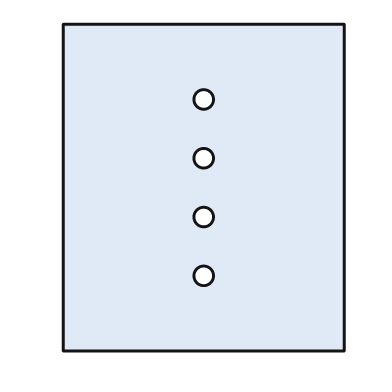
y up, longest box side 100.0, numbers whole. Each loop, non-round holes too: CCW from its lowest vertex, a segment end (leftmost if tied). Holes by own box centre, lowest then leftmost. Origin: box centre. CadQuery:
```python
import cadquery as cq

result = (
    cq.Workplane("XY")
    .moveTo(-43.0, -50.0)
    .lineTo(43.0, -50.0)
    .lineTo(43.0, 50.0)
    .lineTo(-43.0, 50.0)
    .close()
    .moveTo(0.0, -27.0)
    .circle(3.0)
    .moveTo(0.0, -9.0)
    .circle(3.0)
    .moveTo(0.0, 9.0)
    .circle(3.0)
    .moveTo(0.0, 27.0)
    .circle(3.0)
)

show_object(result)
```